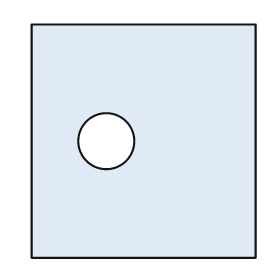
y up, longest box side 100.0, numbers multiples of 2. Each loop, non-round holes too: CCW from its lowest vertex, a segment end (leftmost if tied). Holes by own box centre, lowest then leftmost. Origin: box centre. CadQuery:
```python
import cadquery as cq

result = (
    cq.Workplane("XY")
    .moveTo(-48.0, -50.0)
    .lineTo(48.0, -50.0)
    .lineTo(48.0, 50.0)
    .lineTo(-48.0, 50.0)
    .close()
    .moveTo(-16.0, 0.0)
    .circle(12.0)
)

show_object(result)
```